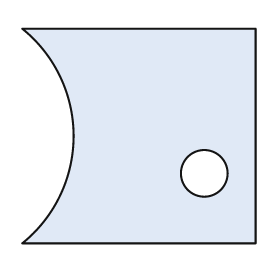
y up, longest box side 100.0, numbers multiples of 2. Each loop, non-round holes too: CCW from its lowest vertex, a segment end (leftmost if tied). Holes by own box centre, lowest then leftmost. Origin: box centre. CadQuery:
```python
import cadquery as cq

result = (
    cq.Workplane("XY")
    .moveTo(-50.0, -46.0)
    .lineTo(50.0, -46.0)
    .lineTo(50.0, 46.0)
    .lineTo(-50.0, 46.0)
    .threePointArc((-28.0, 0.0), (-50.0, -46.0))
    .close()
    .moveTo(28.0, -16.0)
    .circle(10.0)
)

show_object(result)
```